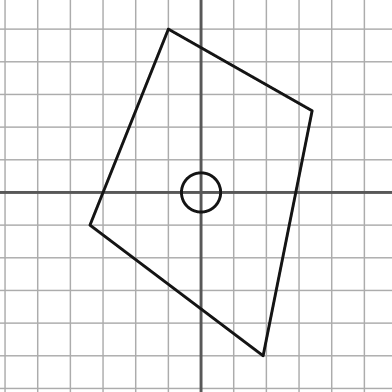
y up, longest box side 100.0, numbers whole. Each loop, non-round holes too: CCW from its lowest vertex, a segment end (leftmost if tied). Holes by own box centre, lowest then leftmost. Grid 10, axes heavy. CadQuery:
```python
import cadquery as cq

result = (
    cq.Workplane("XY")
    .moveTo(19.0, -50.0)
    .lineTo(34.0, 25.0)
    .lineTo(-10.0, 50.0)
    .lineTo(-34.0, -10.0)
    .close()
    .moveTo(0.0, 0.0)
    .circle(6.0)
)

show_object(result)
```